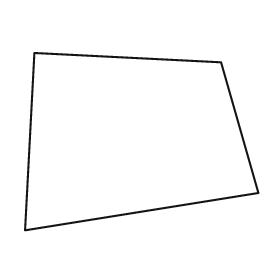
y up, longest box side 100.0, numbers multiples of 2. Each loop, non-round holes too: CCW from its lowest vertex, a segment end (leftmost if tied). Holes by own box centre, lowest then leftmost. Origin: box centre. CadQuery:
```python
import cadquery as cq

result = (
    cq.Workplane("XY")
    .moveTo(-50.0, -38.0)
    .lineTo(50.0, -22.0)
    .lineTo(34.0, 34.0)
    .lineTo(-46.0, 38.0)
    .close()
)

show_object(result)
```